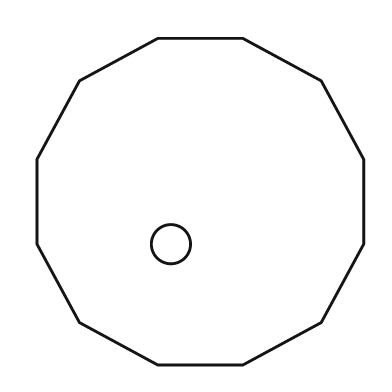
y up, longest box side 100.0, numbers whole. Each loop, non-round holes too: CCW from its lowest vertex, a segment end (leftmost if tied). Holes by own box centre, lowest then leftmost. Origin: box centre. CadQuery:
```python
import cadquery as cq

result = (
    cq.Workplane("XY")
    .moveTo(-13.0, -50.0)
    .lineTo(13.0, -50.0)
    .lineTo(37.0, -37.0)
    .lineTo(50.0, -13.0)
    .lineTo(50.0, 13.0)
    .lineTo(37.0, 37.0)
    .lineTo(13.0, 50.0)
    .lineTo(-13.0, 50.0)
    .lineTo(-37.0, 37.0)
    .lineTo(-50.0, 13.0)
    .lineTo(-50.0, -13.0)
    .lineTo(-37.0, -37.0)
    .close()
    .moveTo(-9.0, -13.0)
    .circle(6.0)
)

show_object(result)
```